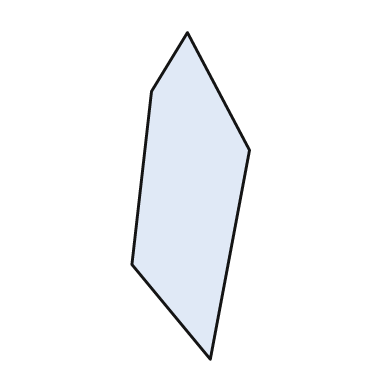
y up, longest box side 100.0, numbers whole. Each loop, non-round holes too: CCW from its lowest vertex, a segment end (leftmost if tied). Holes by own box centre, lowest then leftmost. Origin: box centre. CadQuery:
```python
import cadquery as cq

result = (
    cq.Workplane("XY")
    .moveTo(6.0, -50.0)
    .lineTo(18.0, 14.0)
    .lineTo(-1.0, 50.0)
    .lineTo(-12.0, 32.0)
    .lineTo(-18.0, -21.0)
    .close()
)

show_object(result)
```